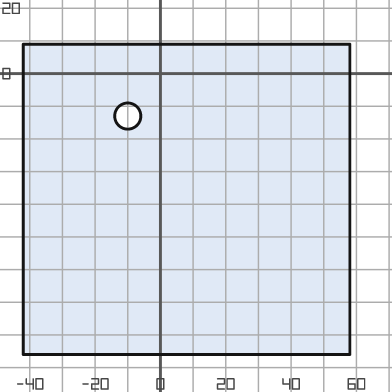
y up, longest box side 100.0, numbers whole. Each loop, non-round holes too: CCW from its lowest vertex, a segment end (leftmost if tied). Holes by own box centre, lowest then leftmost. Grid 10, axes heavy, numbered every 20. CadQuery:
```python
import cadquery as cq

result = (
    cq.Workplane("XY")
    .moveTo(-42.0, -86.0)
    .lineTo(58.0, -86.0)
    .lineTo(58.0, 9.0)
    .lineTo(-42.0, 9.0)
    .close()
    .moveTo(-10.0, -13.0)
    .circle(4.0)
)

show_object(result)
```